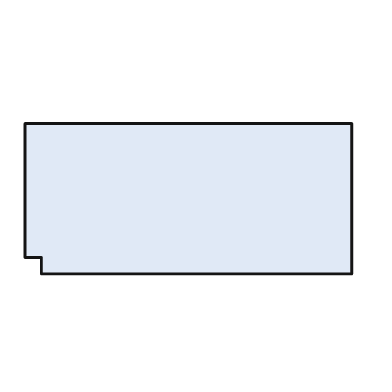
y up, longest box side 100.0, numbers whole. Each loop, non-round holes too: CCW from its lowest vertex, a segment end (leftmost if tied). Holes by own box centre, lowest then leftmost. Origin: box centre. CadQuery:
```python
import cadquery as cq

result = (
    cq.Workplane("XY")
    .moveTo(-45.0, -23.0)
    .lineTo(50.0, -23.0)
    .lineTo(50.0, 23.0)
    .lineTo(-50.0, 23.0)
    .lineTo(-50.0, -18.0)
    .lineTo(-45.0, -18.0)
    .close()
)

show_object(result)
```